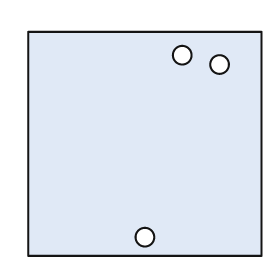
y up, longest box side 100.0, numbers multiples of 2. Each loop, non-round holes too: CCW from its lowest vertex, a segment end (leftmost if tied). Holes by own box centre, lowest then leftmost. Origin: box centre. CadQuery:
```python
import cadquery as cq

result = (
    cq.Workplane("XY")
    .moveTo(-50.0, -48.0)
    .lineTo(50.0, -48.0)
    .lineTo(50.0, 48.0)
    .lineTo(-50.0, 48.0)
    .close()
    .moveTo(0.0, -40.0)
    .circle(4.0)
    .moveTo(32.0, 34.0)
    .circle(4.0)
    .moveTo(16.0, 38.0)
    .circle(4.0)
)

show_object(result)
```